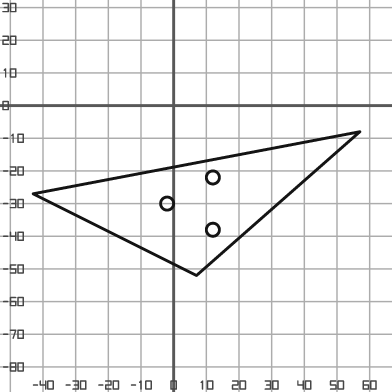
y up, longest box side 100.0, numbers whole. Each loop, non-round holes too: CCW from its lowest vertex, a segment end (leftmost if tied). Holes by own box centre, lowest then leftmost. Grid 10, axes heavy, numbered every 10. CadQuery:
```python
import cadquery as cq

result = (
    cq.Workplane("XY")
    .moveTo(7.0, -52.0)
    .lineTo(57.0, -8.0)
    .lineTo(-43.0, -27.0)
    .close()
    .moveTo(12.0, -38.0)
    .circle(2.0)
    .moveTo(-2.0, -30.0)
    .circle(2.0)
    .moveTo(12.0, -22.0)
    .circle(2.0)
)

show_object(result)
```